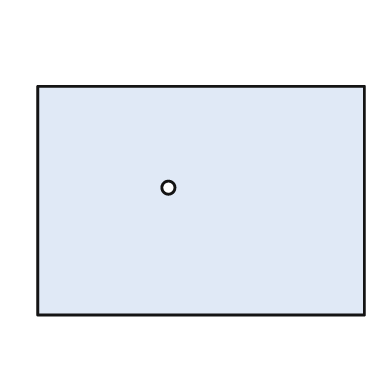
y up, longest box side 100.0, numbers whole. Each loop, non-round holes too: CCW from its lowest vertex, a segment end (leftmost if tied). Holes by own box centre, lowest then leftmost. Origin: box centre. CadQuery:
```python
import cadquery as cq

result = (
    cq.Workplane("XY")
    .moveTo(-50.0, -35.0)
    .lineTo(50.0, -35.0)
    .lineTo(50.0, 35.0)
    .lineTo(-50.0, 35.0)
    .close()
    .moveTo(-10.0, 4.0)
    .circle(2.0)
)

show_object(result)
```